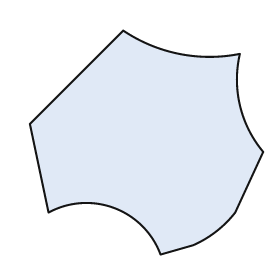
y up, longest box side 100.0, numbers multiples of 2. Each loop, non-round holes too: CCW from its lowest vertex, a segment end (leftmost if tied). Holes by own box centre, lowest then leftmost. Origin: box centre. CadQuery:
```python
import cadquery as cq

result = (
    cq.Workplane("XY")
    .moveTo(6.0, -48.0)
    .lineTo(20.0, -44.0)
    .threePointArc((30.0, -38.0), (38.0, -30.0))
    .lineTo(50.0, -4.0)
    .threePointArc((40.0, 16.0), (40.0, 38.0))
    .threePointArc((14.0, 38.0), (-10.0, 48.0))
    .lineTo(-50.0, 8.0)
    .lineTo(-42.0, -30.0)
    .threePointArc((-14.0, -28.0), (6.0, -48.0))
    .close()
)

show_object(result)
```